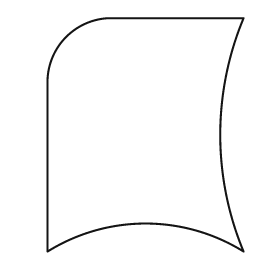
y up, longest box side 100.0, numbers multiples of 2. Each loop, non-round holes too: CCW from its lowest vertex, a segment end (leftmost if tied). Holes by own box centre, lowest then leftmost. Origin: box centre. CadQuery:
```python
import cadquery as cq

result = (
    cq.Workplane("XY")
    .moveTo(-42.0, -50.0)
    .threePointArc((0.0, -38.0), (42.0, -50.0))
    .threePointArc((32.0, 0.0), (42.0, 50.0))
    .lineTo(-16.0, 50.0)
    .threePointArc((-34.0, 42.0), (-42.0, 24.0))
    .close()
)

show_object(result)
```